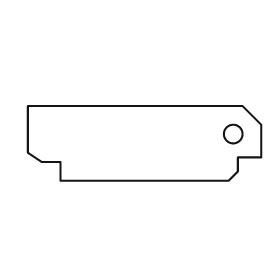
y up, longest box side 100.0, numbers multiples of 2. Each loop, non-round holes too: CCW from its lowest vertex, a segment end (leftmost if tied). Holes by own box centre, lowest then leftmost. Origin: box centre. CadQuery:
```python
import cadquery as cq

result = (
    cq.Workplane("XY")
    .moveTo(-36.0, -16.0)
    .lineTo(36.0, -16.0)
    .lineTo(40.0, -12.0)
    .lineTo(40.0, -6.0)
    .lineTo(50.0, -6.0)
    .lineTo(50.0, 8.0)
    .lineTo(42.0, 16.0)
    .lineTo(-50.0, 16.0)
    .lineTo(-50.0, -4.0)
    .lineTo(-44.0, -8.0)
    .lineTo(-36.0, -8.0)
    .close()
    .moveTo(38.0, 4.0)
    .circle(4.0)
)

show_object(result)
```